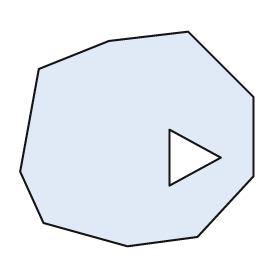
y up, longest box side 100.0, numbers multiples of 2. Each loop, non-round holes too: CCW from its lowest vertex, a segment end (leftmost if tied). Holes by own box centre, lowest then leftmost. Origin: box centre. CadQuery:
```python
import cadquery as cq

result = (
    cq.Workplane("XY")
    .moveTo(-4.0, -46.0)
    .lineTo(26.0, -42.0)
    .lineTo(50.0, -16.0)
    .lineTo(50.0, 18.0)
    .lineTo(22.0, 46.0)
    .lineTo(-12.0, 42.0)
    .lineTo(-42.0, 30.0)
    .lineTo(-50.0, -14.0)
    .lineTo(-40.0, -36.0)
    .close()
    .moveTo(14.0, -20.0)
    .lineTo(36.0, -8.0)
    .lineTo(14.0, 4.0)
    .close()
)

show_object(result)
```